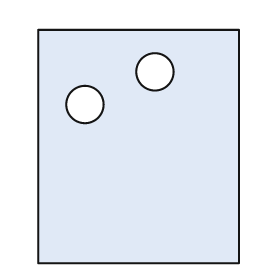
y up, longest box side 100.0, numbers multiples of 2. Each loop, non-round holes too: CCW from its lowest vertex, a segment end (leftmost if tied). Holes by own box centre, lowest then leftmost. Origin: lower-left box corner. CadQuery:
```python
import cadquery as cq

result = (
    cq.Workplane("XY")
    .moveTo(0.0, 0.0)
    .lineTo(86.0, 0.0)
    .lineTo(86.0, 100.0)
    .lineTo(0.0, 100.0)
    .close()
    .moveTo(20.0, 68.0)
    .circle(8.0)
    .moveTo(50.0, 82.0)
    .circle(8.0)
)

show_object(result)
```